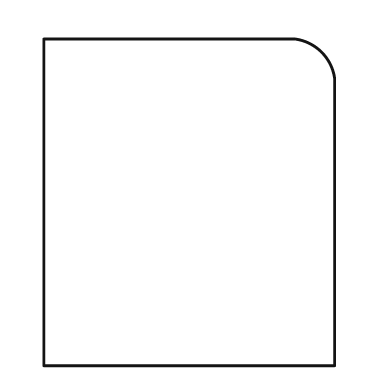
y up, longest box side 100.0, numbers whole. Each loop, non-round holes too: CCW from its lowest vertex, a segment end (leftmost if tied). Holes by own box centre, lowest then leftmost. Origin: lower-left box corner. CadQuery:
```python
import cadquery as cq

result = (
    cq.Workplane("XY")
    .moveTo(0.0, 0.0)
    .lineTo(89.0, 0.0)
    .lineTo(89.0, 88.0)
    .threePointArc((85.0, 96.0), (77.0, 100.0))
    .lineTo(0.0, 100.0)
    .close()
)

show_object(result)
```